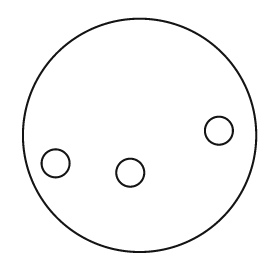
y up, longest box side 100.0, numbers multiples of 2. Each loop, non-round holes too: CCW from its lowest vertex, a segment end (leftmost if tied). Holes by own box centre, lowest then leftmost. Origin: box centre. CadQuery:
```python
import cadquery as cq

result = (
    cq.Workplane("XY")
    .moveTo(0.0, 0.0)
    .circle(50.0)
    .moveTo(-4.0, -16.0)
    .circle(6.0)
    .moveTo(-36.0, -12.0)
    .circle(6.0)
    .moveTo(34.0, 2.0)
    .circle(6.0)
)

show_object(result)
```